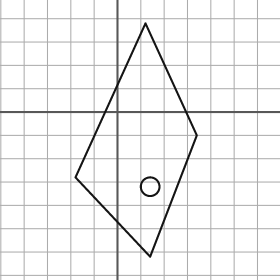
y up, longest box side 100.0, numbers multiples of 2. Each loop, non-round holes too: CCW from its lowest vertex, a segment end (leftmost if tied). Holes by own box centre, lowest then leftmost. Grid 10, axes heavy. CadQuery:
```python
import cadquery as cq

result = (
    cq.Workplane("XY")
    .moveTo(14.0, -62.0)
    .lineTo(34.0, -10.0)
    .lineTo(12.0, 38.0)
    .lineTo(-18.0, -28.0)
    .close()
    .moveTo(14.0, -32.0)
    .circle(4.0)
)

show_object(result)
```